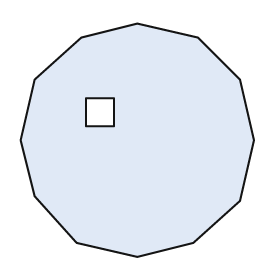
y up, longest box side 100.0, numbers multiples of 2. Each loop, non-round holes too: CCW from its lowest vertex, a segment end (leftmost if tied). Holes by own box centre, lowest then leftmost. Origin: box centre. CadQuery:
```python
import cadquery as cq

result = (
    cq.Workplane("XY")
    .moveTo(0.0, -50.0)
    .lineTo(24.0, -44.0)
    .lineTo(44.0, -26.0)
    .lineTo(50.0, 0.0)
    .lineTo(44.0, 26.0)
    .lineTo(26.0, 44.0)
    .lineTo(0.0, 50.0)
    .lineTo(-24.0, 44.0)
    .lineTo(-44.0, 26.0)
    .lineTo(-50.0, 0.0)
    .lineTo(-44.0, -24.0)
    .lineTo(-26.0, -44.0)
    .close()
    .moveTo(-22.0, 6.0)
    .lineTo(-10.0, 6.0)
    .lineTo(-10.0, 18.0)
    .lineTo(-22.0, 18.0)
    .close()
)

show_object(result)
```